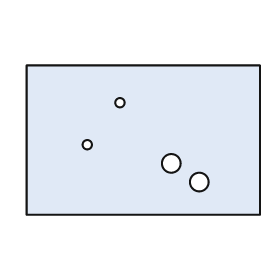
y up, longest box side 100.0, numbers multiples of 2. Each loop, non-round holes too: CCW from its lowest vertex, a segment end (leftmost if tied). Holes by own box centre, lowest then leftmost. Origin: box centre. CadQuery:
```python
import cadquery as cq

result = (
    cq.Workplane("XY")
    .moveTo(-50.0, -32.0)
    .lineTo(50.0, -32.0)
    .lineTo(50.0, 32.0)
    .lineTo(-50.0, 32.0)
    .close()
    .moveTo(24.0, -18.0)
    .circle(4.0)
    .moveTo(12.0, -10.0)
    .circle(4.0)
    .moveTo(-24.0, -2.0)
    .circle(2.0)
    .moveTo(-10.0, 16.0)
    .circle(2.0)
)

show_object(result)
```